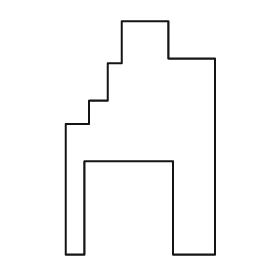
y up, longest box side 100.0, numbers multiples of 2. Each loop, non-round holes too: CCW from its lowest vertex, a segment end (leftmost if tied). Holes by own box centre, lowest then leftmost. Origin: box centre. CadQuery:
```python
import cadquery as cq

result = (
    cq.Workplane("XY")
    .moveTo(-32.0, -50.0)
    .lineTo(-24.0, -50.0)
    .lineTo(-24.0, -10.0)
    .lineTo(14.0, -10.0)
    .lineTo(14.0, -50.0)
    .lineTo(32.0, -50.0)
    .lineTo(32.0, 34.0)
    .lineTo(12.0, 34.0)
    .lineTo(12.0, 50.0)
    .lineTo(-8.0, 50.0)
    .lineTo(-8.0, 32.0)
    .lineTo(-14.0, 32.0)
    .lineTo(-14.0, 16.0)
    .lineTo(-22.0, 16.0)
    .lineTo(-22.0, 6.0)
    .lineTo(-32.0, 6.0)
    .close()
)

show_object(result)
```